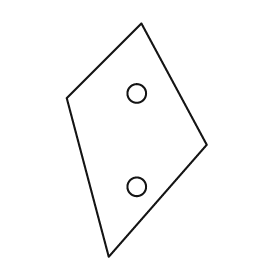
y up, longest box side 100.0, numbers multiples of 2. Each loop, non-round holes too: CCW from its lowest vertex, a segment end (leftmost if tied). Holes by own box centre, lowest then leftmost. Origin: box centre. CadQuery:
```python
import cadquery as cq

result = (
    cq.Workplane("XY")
    .moveTo(-12.0, -50.0)
    .lineTo(30.0, -2.0)
    .lineTo(2.0, 50.0)
    .lineTo(-30.0, 18.0)
    .close()
    .moveTo(0.0, -20.0)
    .circle(4.0)
    .moveTo(0.0, 20.0)
    .circle(4.0)
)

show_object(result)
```